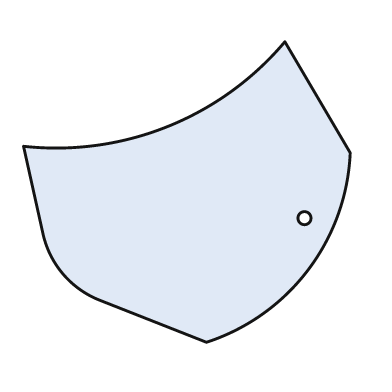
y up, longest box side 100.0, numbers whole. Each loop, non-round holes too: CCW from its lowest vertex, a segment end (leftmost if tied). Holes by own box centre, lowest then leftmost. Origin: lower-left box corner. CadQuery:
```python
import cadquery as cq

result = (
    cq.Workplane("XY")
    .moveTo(56.0, 0.0)
    .threePointArc((87.0, 22.0), (100.0, 58.0))
    .lineTo(80.0, 92.0)
    .threePointArc((44.0, 66.0), (0.0, 60.0))
    .lineTo(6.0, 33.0)
    .threePointArc((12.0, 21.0), (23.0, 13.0))
    .close()
    .moveTo(86.0, 38.0)
    .circle(2.0)
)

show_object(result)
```